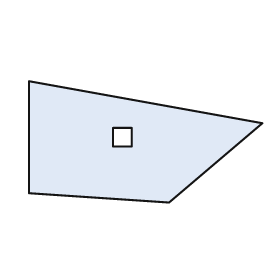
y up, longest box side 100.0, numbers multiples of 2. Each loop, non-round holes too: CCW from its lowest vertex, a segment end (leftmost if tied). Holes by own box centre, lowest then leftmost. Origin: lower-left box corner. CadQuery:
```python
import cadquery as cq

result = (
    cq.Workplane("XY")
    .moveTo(60.0, 0.0)
    .lineTo(100.0, 34.0)
    .lineTo(0.0, 52.0)
    .lineTo(0.0, 4.0)
    .close()
    .moveTo(36.0, 24.0)
    .lineTo(44.0, 24.0)
    .lineTo(44.0, 32.0)
    .lineTo(36.0, 32.0)
    .close()
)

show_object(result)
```